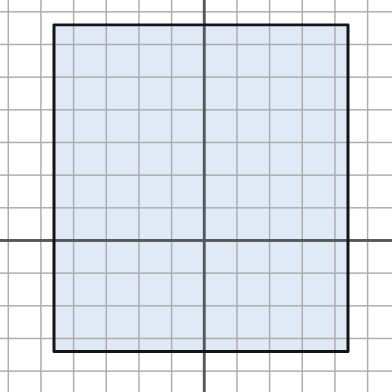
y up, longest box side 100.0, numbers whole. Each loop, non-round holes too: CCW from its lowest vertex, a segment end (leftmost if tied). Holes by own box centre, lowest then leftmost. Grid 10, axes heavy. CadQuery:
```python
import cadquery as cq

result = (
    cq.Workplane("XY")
    .moveTo(-46.0, -34.0)
    .lineTo(44.0, -34.0)
    .lineTo(44.0, 66.0)
    .lineTo(-46.0, 66.0)
    .close()
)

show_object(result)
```